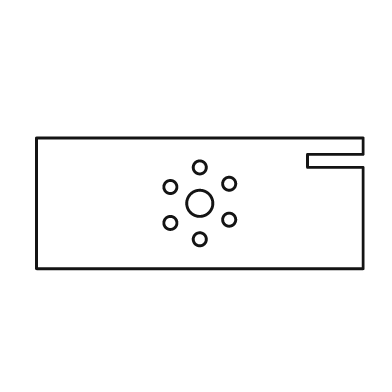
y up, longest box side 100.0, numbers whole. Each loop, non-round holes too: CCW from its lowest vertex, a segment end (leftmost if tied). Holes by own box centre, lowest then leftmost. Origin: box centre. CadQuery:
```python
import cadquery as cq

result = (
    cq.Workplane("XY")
    .moveTo(-50.0, -20.0)
    .lineTo(50.0, -20.0)
    .lineTo(50.0, 11.0)
    .lineTo(33.0, 11.0)
    .lineTo(33.0, 15.0)
    .lineTo(50.0, 15.0)
    .lineTo(50.0, 20.0)
    .lineTo(-50.0, 20.0)
    .close()
    .moveTo(0.0, -11.0)
    .circle(2.0)
    .moveTo(-9.0, -6.0)
    .circle(2.0)
    .moveTo(9.0, -5.0)
    .circle(2.0)
    .moveTo(0.0, 0.0)
    .circle(4.0)
    .moveTo(-9.0, 5.0)
    .circle(2.0)
    .moveTo(9.0, 6.0)
    .circle(2.0)
    .moveTo(0.0, 11.0)
    .circle(2.0)
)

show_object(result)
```